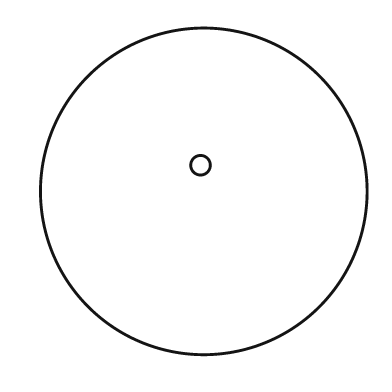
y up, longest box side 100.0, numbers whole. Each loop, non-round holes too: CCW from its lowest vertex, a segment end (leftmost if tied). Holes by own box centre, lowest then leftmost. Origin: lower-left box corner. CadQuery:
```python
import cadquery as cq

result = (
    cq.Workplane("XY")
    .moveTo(50.0, 50.0)
    .circle(50.0)
    .moveTo(49.0, 58.0)
    .circle(3.0)
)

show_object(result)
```